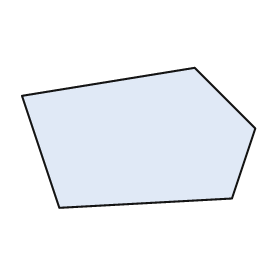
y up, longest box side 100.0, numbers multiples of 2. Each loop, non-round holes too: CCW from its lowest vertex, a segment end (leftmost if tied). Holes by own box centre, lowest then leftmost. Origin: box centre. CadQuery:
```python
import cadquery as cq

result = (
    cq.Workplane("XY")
    .moveTo(-34.0, -30.0)
    .lineTo(40.0, -26.0)
    .lineTo(50.0, 4.0)
    .lineTo(24.0, 30.0)
    .lineTo(-50.0, 18.0)
    .close()
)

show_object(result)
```